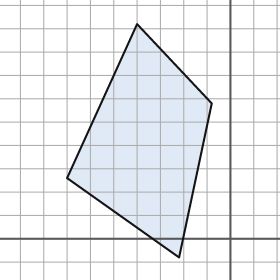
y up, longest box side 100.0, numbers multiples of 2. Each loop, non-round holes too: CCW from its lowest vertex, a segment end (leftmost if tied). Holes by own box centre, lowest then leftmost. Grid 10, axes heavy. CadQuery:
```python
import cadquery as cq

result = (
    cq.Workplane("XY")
    .moveTo(-22.0, -8.0)
    .lineTo(-8.0, 58.0)
    .lineTo(-40.0, 92.0)
    .lineTo(-70.0, 26.0)
    .close()
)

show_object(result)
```